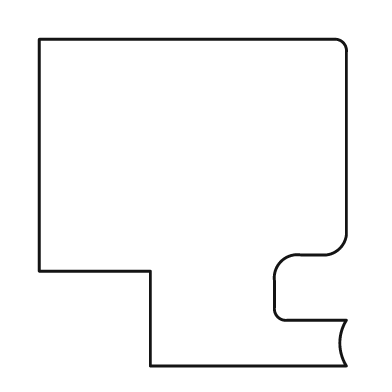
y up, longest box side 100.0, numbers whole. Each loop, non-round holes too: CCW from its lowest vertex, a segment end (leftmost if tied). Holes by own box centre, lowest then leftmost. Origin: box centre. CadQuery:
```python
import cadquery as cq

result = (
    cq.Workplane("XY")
    .moveTo(-13.0, -50.0)
    .lineTo(47.0, -50.0)
    .threePointArc((45.0, -43.0), (47.0, -36.0))
    .lineTo(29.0, -36.0)
    .threePointArc((26.0, -35.0), (25.0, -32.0))
    .lineTo(25.0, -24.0)
    .threePointArc((27.0, -18.0), (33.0, -16.0))
    .lineTo(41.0, -16.0)
    .threePointArc((45.0, -14.0), (47.0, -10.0))
    .lineTo(47.0, 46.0)
    .threePointArc((46.0, 49.0), (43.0, 50.0))
    .lineTo(-47.0, 50.0)
    .lineTo(-47.0, -21.0)
    .lineTo(-13.0, -21.0)
    .close()
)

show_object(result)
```